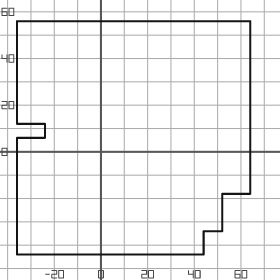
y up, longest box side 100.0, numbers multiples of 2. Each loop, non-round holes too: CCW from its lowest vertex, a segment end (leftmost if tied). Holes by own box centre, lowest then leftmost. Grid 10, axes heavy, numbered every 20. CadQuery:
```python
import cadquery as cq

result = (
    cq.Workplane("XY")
    .moveTo(-36.0, -44.0)
    .lineTo(44.0, -44.0)
    .lineTo(44.0, -34.0)
    .lineTo(52.0, -34.0)
    .lineTo(52.0, -18.0)
    .lineTo(64.0, -18.0)
    .lineTo(64.0, 56.0)
    .lineTo(-36.0, 56.0)
    .lineTo(-36.0, 12.0)
    .lineTo(-24.0, 12.0)
    .lineTo(-24.0, 6.0)
    .lineTo(-36.0, 6.0)
    .close()
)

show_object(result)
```